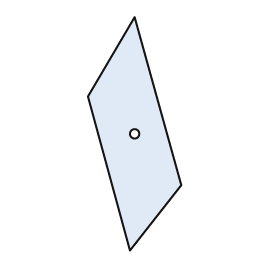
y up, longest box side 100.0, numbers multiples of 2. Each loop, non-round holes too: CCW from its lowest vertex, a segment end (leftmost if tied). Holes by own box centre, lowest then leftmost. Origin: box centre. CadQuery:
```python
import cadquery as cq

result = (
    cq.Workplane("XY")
    .moveTo(-2.0, -50.0)
    .lineTo(20.0, -22.0)
    .lineTo(0.0, 50.0)
    .lineTo(-20.0, 16.0)
    .close()
    .moveTo(0.0, 0.0)
    .circle(2.0)
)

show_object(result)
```